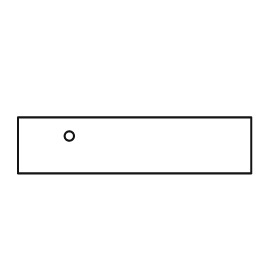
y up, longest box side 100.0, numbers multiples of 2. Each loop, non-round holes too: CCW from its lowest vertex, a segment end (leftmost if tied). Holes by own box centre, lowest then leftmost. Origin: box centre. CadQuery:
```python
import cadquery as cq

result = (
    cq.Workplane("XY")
    .moveTo(-50.0, -12.0)
    .lineTo(50.0, -12.0)
    .lineTo(50.0, 12.0)
    .lineTo(-50.0, 12.0)
    .close()
    .moveTo(-28.0, 4.0)
    .circle(2.0)
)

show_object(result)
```